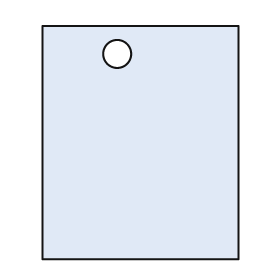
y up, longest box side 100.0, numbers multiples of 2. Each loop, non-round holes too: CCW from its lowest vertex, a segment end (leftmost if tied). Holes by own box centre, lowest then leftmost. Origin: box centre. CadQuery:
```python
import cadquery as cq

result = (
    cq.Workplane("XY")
    .moveTo(-42.0, -50.0)
    .lineTo(42.0, -50.0)
    .lineTo(42.0, 50.0)
    .lineTo(-42.0, 50.0)
    .close()
    .moveTo(-10.0, 38.0)
    .circle(6.0)
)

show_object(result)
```